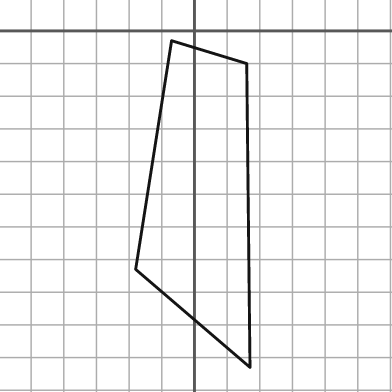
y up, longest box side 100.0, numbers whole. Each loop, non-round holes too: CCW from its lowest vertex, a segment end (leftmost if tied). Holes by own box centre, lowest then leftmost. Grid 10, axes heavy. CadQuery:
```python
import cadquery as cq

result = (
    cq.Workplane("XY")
    .moveTo(17.0, -103.0)
    .lineTo(16.0, -10.0)
    .lineTo(-7.0, -3.0)
    .lineTo(-18.0, -73.0)
    .close()
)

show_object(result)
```